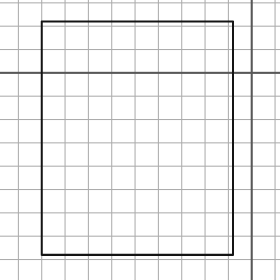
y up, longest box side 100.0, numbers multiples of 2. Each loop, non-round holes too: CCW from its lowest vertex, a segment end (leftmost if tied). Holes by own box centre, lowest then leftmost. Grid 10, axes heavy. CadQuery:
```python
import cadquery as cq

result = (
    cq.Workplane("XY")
    .moveTo(-90.0, -78.0)
    .lineTo(-8.0, -78.0)
    .lineTo(-8.0, 22.0)
    .lineTo(-90.0, 22.0)
    .close()
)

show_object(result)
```